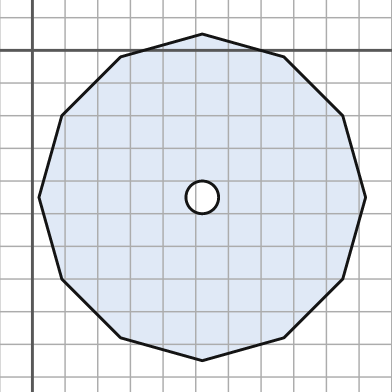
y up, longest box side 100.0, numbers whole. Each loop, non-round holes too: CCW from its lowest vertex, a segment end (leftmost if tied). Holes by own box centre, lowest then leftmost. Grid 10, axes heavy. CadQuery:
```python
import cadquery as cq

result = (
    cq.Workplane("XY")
    .moveTo(52.0, -95.0)
    .lineTo(77.0, -88.0)
    .lineTo(95.0, -70.0)
    .lineTo(102.0, -45.0)
    .lineTo(95.0, -20.0)
    .lineTo(77.0, -2.0)
    .lineTo(52.0, 5.0)
    .lineTo(27.0, -2.0)
    .lineTo(9.0, -20.0)
    .lineTo(2.0, -45.0)
    .lineTo(9.0, -70.0)
    .lineTo(27.0, -88.0)
    .close()
    .moveTo(52.0, -45.0)
    .circle(5.0)
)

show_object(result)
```